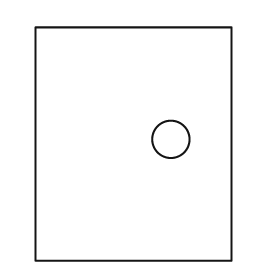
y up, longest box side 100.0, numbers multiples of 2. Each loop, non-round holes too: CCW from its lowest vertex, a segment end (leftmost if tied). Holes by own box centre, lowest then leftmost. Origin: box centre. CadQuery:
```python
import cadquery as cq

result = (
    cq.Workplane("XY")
    .moveTo(-42.0, -50.0)
    .lineTo(42.0, -50.0)
    .lineTo(42.0, 50.0)
    .lineTo(-42.0, 50.0)
    .close()
    .moveTo(16.0, 2.0)
    .circle(8.0)
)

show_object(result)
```